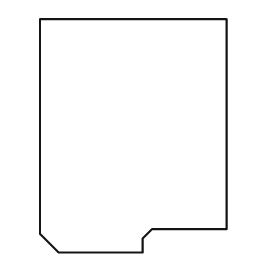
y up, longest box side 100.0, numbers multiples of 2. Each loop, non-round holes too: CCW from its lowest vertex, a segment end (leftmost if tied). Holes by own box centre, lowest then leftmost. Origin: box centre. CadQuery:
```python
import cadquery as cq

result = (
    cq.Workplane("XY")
    .moveTo(-32.0, -50.0)
    .lineTo(4.0, -50.0)
    .lineTo(4.0, -44.0)
    .lineTo(8.0, -40.0)
    .lineTo(40.0, -40.0)
    .lineTo(40.0, 50.0)
    .lineTo(-40.0, 50.0)
    .lineTo(-40.0, -42.0)
    .close()
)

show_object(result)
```